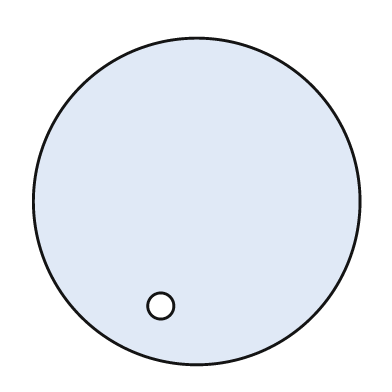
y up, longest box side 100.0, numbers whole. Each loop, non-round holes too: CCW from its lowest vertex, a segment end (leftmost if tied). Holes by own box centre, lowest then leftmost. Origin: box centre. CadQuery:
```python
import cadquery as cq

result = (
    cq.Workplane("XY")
    .moveTo(0.0, 0.0)
    .circle(50.0)
    .moveTo(-11.0, -32.0)
    .circle(4.0)
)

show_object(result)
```